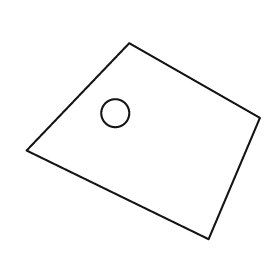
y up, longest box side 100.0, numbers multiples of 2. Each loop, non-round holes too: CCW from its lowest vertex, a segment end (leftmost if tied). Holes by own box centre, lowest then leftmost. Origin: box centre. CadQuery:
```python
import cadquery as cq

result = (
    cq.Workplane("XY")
    .moveTo(28.0, -42.0)
    .lineTo(50.0, 10.0)
    .lineTo(-6.0, 42.0)
    .lineTo(-50.0, -4.0)
    .close()
    .moveTo(-12.0, 12.0)
    .circle(6.0)
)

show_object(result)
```